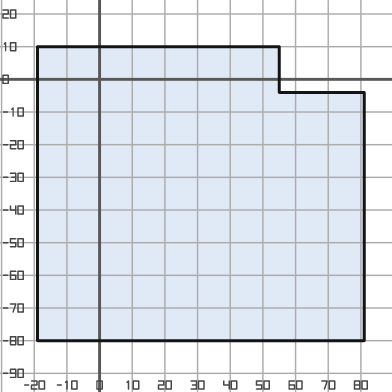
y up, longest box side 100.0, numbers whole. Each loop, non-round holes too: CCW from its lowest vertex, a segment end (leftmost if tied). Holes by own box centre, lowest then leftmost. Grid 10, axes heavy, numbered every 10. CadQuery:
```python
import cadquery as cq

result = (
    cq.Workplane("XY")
    .moveTo(-19.0, -80.0)
    .lineTo(81.0, -80.0)
    .lineTo(81.0, -4.0)
    .lineTo(55.0, -4.0)
    .lineTo(55.0, 10.0)
    .lineTo(-19.0, 10.0)
    .close()
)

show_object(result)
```